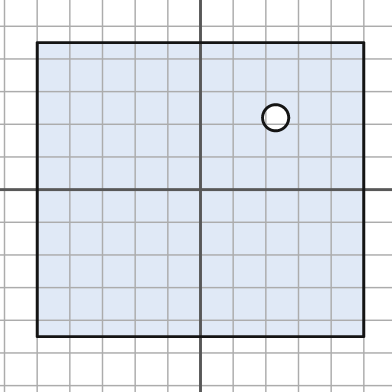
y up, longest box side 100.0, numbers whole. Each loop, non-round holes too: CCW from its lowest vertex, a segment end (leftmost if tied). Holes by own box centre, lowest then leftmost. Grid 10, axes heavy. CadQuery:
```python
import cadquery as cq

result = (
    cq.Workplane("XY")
    .moveTo(-50.0, -45.0)
    .lineTo(50.0, -45.0)
    .lineTo(50.0, 45.0)
    .lineTo(-50.0, 45.0)
    .close()
    .moveTo(23.0, 22.0)
    .circle(4.0)
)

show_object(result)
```